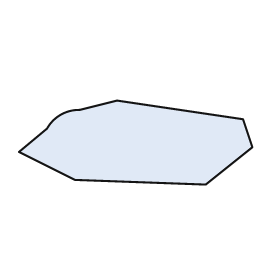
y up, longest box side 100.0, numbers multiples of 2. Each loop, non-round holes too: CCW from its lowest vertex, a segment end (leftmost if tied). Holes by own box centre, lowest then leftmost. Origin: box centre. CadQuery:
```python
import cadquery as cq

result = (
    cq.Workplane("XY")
    .moveTo(30.0, -18.0)
    .lineTo(50.0, -2.0)
    .lineTo(46.0, 10.0)
    .lineTo(-8.0, 18.0)
    .lineTo(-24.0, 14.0)
    .threePointArc((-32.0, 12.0), (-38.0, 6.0))
    .lineTo(-50.0, -4.0)
    .lineTo(-26.0, -16.0)
    .close()
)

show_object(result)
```